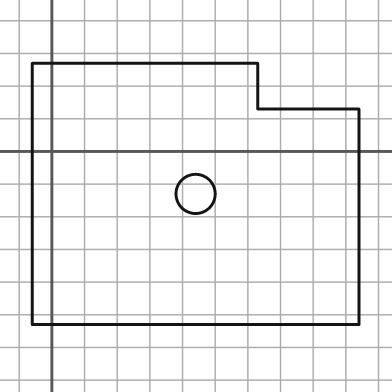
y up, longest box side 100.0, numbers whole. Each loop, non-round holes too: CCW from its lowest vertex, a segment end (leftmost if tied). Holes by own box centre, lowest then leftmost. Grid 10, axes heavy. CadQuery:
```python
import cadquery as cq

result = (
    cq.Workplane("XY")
    .moveTo(-6.0, -53.0)
    .lineTo(94.0, -53.0)
    .lineTo(94.0, 13.0)
    .lineTo(63.0, 13.0)
    .lineTo(63.0, 27.0)
    .lineTo(-6.0, 27.0)
    .close()
    .moveTo(44.0, -13.0)
    .circle(6.0)
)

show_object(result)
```